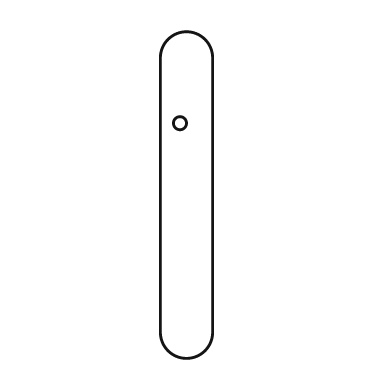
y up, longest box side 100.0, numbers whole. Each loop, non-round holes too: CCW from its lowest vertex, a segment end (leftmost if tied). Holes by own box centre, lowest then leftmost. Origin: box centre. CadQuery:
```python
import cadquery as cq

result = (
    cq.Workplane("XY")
    .moveTo(-8.0, -42.0)
    .threePointArc((0.0, -50.0), (8.0, -42.0))
    .lineTo(8.0, 42.0)
    .threePointArc((0.0, 50.0), (-8.0, 42.0))
    .close()
    .moveTo(-2.0, 22.0)
    .circle(2.0)
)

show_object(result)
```